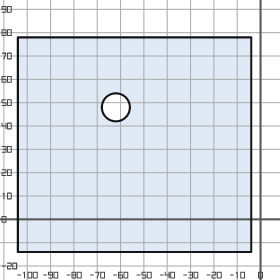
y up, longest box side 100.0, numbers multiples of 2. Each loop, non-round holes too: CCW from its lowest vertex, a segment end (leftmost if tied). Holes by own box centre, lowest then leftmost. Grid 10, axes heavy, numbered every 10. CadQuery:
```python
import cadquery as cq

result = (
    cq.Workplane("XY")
    .moveTo(-104.0, -14.0)
    .lineTo(-4.0, -14.0)
    .lineTo(-4.0, 78.0)
    .lineTo(-104.0, 78.0)
    .close()
    .moveTo(-62.0, 48.0)
    .circle(6.0)
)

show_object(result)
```